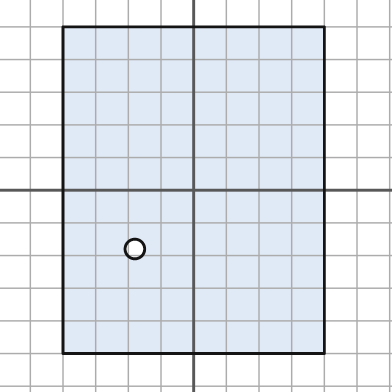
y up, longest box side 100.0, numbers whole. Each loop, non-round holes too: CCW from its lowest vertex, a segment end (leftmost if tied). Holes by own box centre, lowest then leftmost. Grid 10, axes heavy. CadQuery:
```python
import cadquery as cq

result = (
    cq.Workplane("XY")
    .moveTo(-40.0, -50.0)
    .lineTo(40.0, -50.0)
    .lineTo(40.0, 50.0)
    .lineTo(-40.0, 50.0)
    .close()
    .moveTo(-18.0, -18.0)
    .circle(3.0)
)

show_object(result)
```